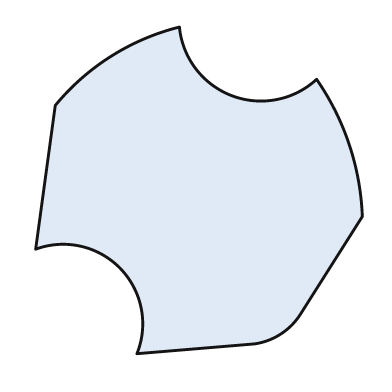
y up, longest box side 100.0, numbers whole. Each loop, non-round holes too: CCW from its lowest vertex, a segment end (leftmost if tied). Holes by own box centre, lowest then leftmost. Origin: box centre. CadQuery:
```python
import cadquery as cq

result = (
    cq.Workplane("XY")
    .moveTo(-19.0, -50.0)
    .lineTo(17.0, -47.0)
    .threePointArc((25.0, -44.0), (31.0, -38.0))
    .lineTo(50.0, -8.0)
    .threePointArc((46.0, 14.0), (36.0, 34.0))
    .threePointArc((10.0, 29.0), (-6.0, 50.0))
    .threePointArc((-27.0, 41.0), (-44.0, 26.0))
    .lineTo(-50.0, -18.0)
    .threePointArc((-24.0, -24.0), (-19.0, -50.0))
    .close()
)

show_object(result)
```